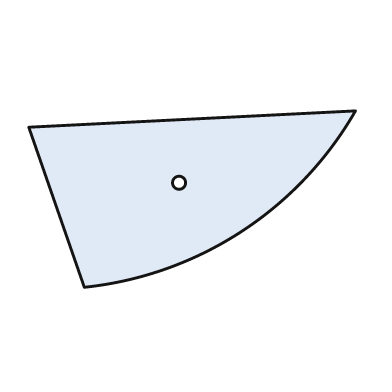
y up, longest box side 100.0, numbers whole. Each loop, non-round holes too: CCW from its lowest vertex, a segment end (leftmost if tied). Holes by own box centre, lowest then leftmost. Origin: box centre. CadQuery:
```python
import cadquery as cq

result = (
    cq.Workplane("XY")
    .moveTo(-33.0, -27.0)
    .threePointArc((15.0, -10.0), (50.0, 27.0))
    .lineTo(-50.0, 22.0)
    .close()
    .moveTo(-4.0, 5.0)
    .circle(2.0)
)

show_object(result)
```